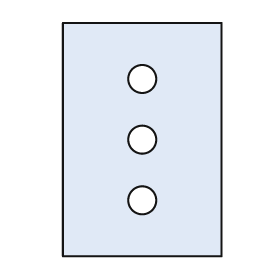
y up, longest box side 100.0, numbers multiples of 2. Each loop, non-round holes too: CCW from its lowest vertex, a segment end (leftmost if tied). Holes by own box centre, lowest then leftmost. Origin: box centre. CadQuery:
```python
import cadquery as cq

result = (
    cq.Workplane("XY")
    .moveTo(-34.0, -50.0)
    .lineTo(34.0, -50.0)
    .lineTo(34.0, 50.0)
    .lineTo(-34.0, 50.0)
    .close()
    .moveTo(0.0, -26.0)
    .circle(6.0)
    .moveTo(0.0, 0.0)
    .circle(6.0)
    .moveTo(0.0, 26.0)
    .circle(6.0)
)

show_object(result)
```